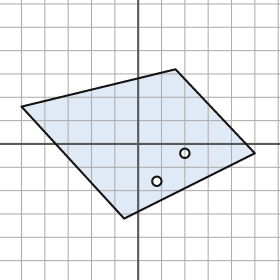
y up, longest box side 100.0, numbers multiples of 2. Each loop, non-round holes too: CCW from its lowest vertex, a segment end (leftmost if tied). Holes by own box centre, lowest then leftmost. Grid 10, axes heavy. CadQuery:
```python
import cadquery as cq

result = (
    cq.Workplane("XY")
    .moveTo(-6.0, -32.0)
    .lineTo(50.0, -4.0)
    .lineTo(16.0, 32.0)
    .lineTo(-50.0, 16.0)
    .close()
    .moveTo(8.0, -16.0)
    .circle(2.0)
    .moveTo(20.0, -4.0)
    .circle(2.0)
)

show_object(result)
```